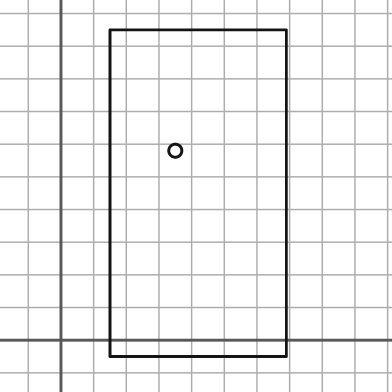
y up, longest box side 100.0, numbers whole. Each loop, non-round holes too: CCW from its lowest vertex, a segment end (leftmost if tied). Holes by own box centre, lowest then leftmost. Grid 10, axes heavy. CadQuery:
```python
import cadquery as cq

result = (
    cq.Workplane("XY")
    .moveTo(15.0, -5.0)
    .lineTo(69.0, -5.0)
    .lineTo(69.0, 95.0)
    .lineTo(15.0, 95.0)
    .close()
    .moveTo(35.0, 58.0)
    .circle(2.0)
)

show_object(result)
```